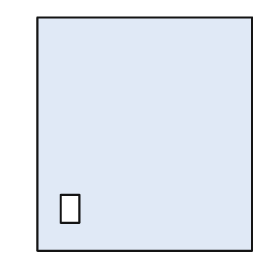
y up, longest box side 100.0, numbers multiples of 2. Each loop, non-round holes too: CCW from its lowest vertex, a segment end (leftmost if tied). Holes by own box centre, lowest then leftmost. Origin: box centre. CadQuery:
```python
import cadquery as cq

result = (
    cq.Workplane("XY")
    .moveTo(-46.0, -50.0)
    .lineTo(46.0, -50.0)
    .lineTo(46.0, 50.0)
    .lineTo(-46.0, 50.0)
    .close()
    .moveTo(-36.0, -38.0)
    .lineTo(-28.0, -38.0)
    .lineTo(-28.0, -26.0)
    .lineTo(-36.0, -26.0)
    .close()
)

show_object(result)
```